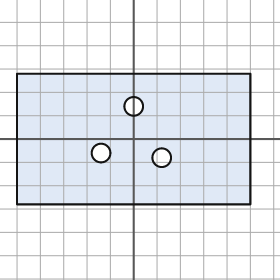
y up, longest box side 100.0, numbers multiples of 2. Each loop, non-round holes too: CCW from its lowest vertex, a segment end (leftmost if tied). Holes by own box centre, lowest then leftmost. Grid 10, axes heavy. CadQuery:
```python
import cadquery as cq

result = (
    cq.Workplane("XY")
    .moveTo(-50.0, -28.0)
    .lineTo(50.0, -28.0)
    .lineTo(50.0, 28.0)
    .lineTo(-50.0, 28.0)
    .close()
    .moveTo(12.0, -8.0)
    .circle(4.0)
    .moveTo(-14.0, -6.0)
    .circle(4.0)
    .moveTo(0.0, 14.0)
    .circle(4.0)
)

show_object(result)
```